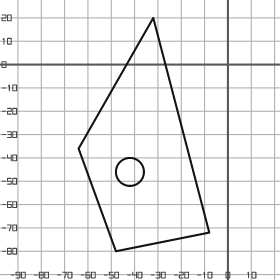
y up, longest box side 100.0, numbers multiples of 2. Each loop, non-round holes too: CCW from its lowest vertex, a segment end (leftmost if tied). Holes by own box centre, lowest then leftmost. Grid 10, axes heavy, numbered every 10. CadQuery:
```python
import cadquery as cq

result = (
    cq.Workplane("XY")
    .moveTo(-48.0, -80.0)
    .lineTo(-8.0, -72.0)
    .lineTo(-32.0, 20.0)
    .lineTo(-64.0, -36.0)
    .close()
    .moveTo(-42.0, -46.0)
    .circle(6.0)
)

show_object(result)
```